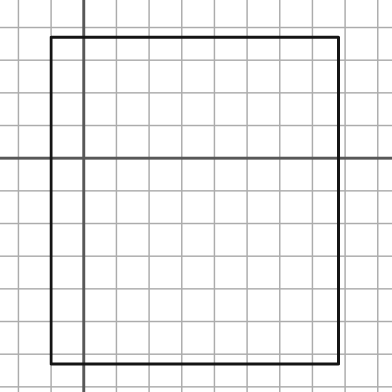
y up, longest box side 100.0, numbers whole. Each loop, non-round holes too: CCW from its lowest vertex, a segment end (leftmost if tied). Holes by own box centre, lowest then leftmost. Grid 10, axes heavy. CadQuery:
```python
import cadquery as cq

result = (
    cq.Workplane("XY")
    .moveTo(-10.0, -63.0)
    .lineTo(78.0, -63.0)
    .lineTo(78.0, 37.0)
    .lineTo(-10.0, 37.0)
    .close()
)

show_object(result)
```